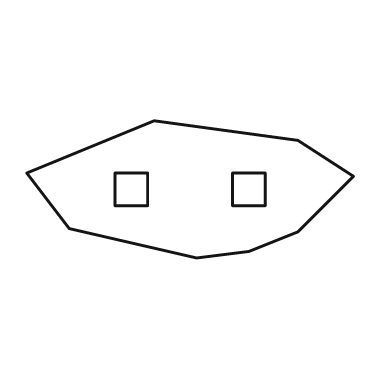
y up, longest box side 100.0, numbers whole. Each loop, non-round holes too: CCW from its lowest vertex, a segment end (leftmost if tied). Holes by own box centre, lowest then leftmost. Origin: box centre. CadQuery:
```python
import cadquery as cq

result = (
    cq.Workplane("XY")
    .moveTo(2.0, -21.0)
    .lineTo(18.0, -19.0)
    .lineTo(33.0, -13.0)
    .lineTo(50.0, 4.0)
    .lineTo(33.0, 15.0)
    .lineTo(-11.0, 21.0)
    .lineTo(-50.0, 5.0)
    .lineTo(-37.0, -12.0)
    .close()
    .moveTo(-23.0, -5.0)
    .lineTo(-13.0, -5.0)
    .lineTo(-13.0, 5.0)
    .lineTo(-23.0, 5.0)
    .close()
    .moveTo(13.0, -5.0)
    .lineTo(23.0, -5.0)
    .lineTo(23.0, 5.0)
    .lineTo(13.0, 5.0)
    .close()
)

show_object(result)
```